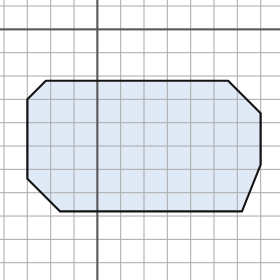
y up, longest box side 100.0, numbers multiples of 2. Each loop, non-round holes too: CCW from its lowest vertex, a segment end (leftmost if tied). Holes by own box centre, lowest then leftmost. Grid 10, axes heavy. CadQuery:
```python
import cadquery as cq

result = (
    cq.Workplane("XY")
    .moveTo(-16.0, -78.0)
    .lineTo(62.0, -78.0)
    .lineTo(70.0, -58.0)
    .lineTo(70.0, -36.0)
    .lineTo(56.0, -22.0)
    .lineTo(-22.0, -22.0)
    .lineTo(-30.0, -30.0)
    .lineTo(-30.0, -64.0)
    .close()
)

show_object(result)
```